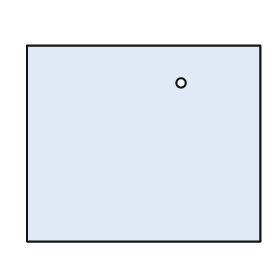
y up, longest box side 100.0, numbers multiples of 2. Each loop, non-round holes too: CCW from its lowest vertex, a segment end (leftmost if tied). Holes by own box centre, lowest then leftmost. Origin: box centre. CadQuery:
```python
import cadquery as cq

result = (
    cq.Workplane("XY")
    .moveTo(-50.0, -42.0)
    .lineTo(50.0, -42.0)
    .lineTo(50.0, 42.0)
    .lineTo(-50.0, 42.0)
    .close()
    .moveTo(16.0, 26.0)
    .circle(2.0)
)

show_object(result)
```